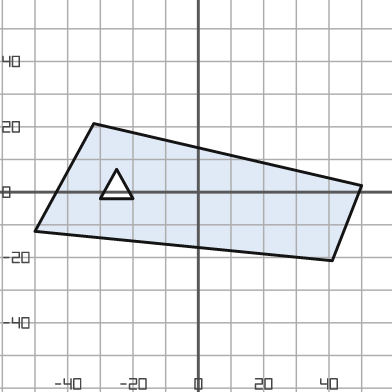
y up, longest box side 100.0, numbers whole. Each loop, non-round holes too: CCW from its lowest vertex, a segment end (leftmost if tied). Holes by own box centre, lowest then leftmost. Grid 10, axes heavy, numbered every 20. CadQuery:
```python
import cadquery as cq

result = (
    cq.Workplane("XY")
    .moveTo(41.0, -21.0)
    .lineTo(50.0, 2.0)
    .lineTo(-32.0, 21.0)
    .lineTo(-50.0, -12.0)
    .close()
    .moveTo(-30.0, -2.0)
    .lineTo(-20.0, -2.0)
    .lineTo(-25.0, 7.0)
    .close()
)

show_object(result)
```